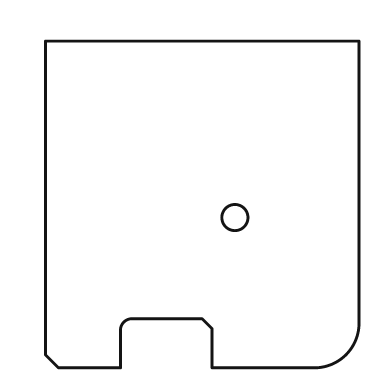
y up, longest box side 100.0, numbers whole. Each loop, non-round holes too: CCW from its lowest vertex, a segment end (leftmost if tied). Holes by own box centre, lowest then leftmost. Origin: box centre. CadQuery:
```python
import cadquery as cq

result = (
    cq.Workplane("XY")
    .moveTo(-44.0, -50.0)
    .lineTo(-25.0, -50.0)
    .lineTo(-25.0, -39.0)
    .threePointArc((-24.0, -36.0), (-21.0, -35.0))
    .lineTo(0.0, -35.0)
    .lineTo(3.0, -38.0)
    .lineTo(3.0, -50.0)
    .lineTo(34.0, -50.0)
    .threePointArc((44.0, -46.0), (48.0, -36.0))
    .lineTo(48.0, 50.0)
    .lineTo(-48.0, 50.0)
    .lineTo(-48.0, -46.0)
    .close()
    .moveTo(10.0, -4.0)
    .circle(4.0)
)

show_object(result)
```